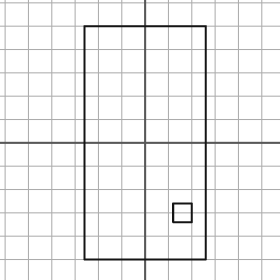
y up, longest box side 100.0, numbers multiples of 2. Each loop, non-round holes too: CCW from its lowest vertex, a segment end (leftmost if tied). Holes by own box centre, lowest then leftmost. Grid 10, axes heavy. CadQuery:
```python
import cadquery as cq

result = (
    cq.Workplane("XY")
    .moveTo(-26.0, -50.0)
    .lineTo(26.0, -50.0)
    .lineTo(26.0, 50.0)
    .lineTo(-26.0, 50.0)
    .close()
    .moveTo(12.0, -34.0)
    .lineTo(20.0, -34.0)
    .lineTo(20.0, -26.0)
    .lineTo(12.0, -26.0)
    .close()
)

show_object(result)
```